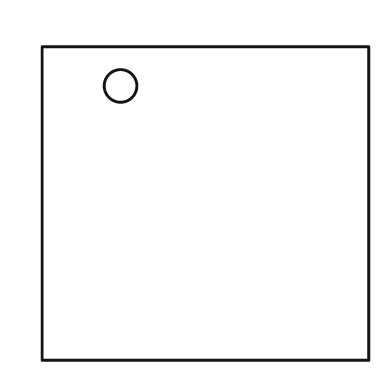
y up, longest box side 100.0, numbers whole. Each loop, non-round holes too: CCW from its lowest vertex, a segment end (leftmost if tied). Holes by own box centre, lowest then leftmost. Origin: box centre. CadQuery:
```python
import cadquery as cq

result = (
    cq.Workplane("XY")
    .moveTo(-50.0, -48.0)
    .lineTo(50.0, -48.0)
    .lineTo(50.0, 48.0)
    .lineTo(-50.0, 48.0)
    .close()
    .moveTo(-26.0, 36.0)
    .circle(5.0)
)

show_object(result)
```